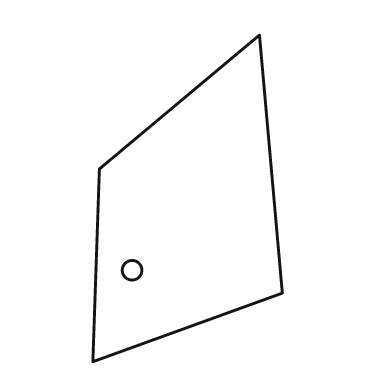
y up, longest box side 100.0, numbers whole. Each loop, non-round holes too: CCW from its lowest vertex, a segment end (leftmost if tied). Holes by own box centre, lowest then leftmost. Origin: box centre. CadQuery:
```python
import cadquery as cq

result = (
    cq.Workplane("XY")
    .moveTo(-29.0, -50.0)
    .lineTo(29.0, -29.0)
    .lineTo(22.0, 50.0)
    .lineTo(-27.0, 9.0)
    .close()
    .moveTo(-17.0, -22.0)
    .circle(3.0)
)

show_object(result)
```